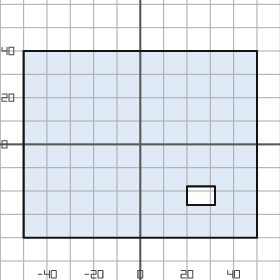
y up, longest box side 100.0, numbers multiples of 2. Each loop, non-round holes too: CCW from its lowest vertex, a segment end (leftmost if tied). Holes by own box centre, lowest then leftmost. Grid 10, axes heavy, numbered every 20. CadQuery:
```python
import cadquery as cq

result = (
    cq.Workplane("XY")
    .moveTo(-50.0, -40.0)
    .lineTo(50.0, -40.0)
    .lineTo(50.0, 40.0)
    .lineTo(-50.0, 40.0)
    .close()
    .moveTo(20.0, -26.0)
    .lineTo(32.0, -26.0)
    .lineTo(32.0, -18.0)
    .lineTo(20.0, -18.0)
    .close()
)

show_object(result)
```